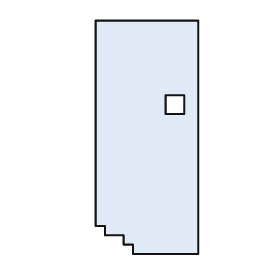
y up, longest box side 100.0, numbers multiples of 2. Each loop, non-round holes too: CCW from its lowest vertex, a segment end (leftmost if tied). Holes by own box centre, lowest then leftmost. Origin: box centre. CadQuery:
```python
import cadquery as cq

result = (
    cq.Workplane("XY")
    .moveTo(-6.0, -50.0)
    .lineTo(22.0, -50.0)
    .lineTo(22.0, 50.0)
    .lineTo(-22.0, 50.0)
    .lineTo(-22.0, -38.0)
    .lineTo(-18.0, -38.0)
    .lineTo(-18.0, -42.0)
    .lineTo(-10.0, -42.0)
    .lineTo(-10.0, -46.0)
    .lineTo(-6.0, -46.0)
    .close()
    .moveTo(8.0, 10.0)
    .lineTo(16.0, 10.0)
    .lineTo(16.0, 18.0)
    .lineTo(8.0, 18.0)
    .close()
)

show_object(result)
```